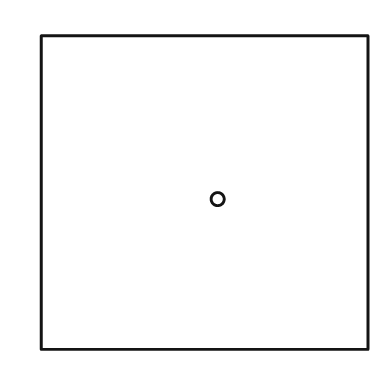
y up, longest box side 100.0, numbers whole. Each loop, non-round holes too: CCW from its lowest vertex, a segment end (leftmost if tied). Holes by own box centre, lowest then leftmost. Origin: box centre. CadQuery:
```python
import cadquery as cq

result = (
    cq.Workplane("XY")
    .moveTo(-50.0, -48.0)
    .lineTo(50.0, -48.0)
    .lineTo(50.0, 48.0)
    .lineTo(-50.0, 48.0)
    .close()
    .moveTo(4.0, -2.0)
    .circle(2.0)
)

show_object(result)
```